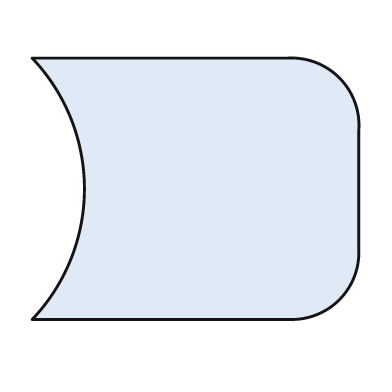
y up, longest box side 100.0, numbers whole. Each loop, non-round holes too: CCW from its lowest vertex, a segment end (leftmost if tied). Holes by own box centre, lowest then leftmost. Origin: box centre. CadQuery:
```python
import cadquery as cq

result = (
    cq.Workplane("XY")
    .moveTo(-50.0, -40.0)
    .lineTo(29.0, -40.0)
    .threePointArc((44.0, -34.0), (50.0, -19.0))
    .lineTo(50.0, 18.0)
    .threePointArc((44.0, 34.0), (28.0, 40.0))
    .lineTo(-50.0, 40.0)
    .threePointArc((-34.0, 0.0), (-50.0, -40.0))
    .close()
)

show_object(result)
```